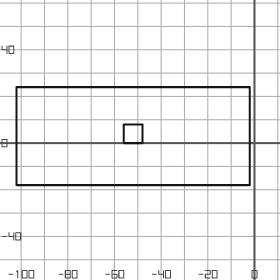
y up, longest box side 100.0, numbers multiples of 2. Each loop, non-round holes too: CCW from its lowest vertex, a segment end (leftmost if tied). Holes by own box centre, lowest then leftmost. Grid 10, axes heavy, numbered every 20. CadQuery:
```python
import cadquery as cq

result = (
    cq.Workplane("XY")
    .moveTo(-102.0, -18.0)
    .lineTo(-2.0, -18.0)
    .lineTo(-2.0, 24.0)
    .lineTo(-102.0, 24.0)
    .close()
    .moveTo(-56.0, 0.0)
    .lineTo(-48.0, 0.0)
    .lineTo(-48.0, 8.0)
    .lineTo(-56.0, 8.0)
    .close()
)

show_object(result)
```